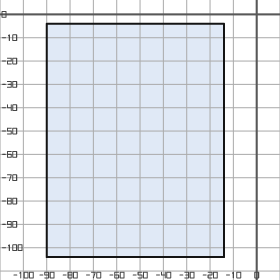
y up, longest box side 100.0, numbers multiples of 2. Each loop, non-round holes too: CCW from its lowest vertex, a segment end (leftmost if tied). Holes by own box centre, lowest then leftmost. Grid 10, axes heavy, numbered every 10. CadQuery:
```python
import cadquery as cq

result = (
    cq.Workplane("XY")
    .moveTo(-90.0, -104.0)
    .lineTo(-14.0, -104.0)
    .lineTo(-14.0, -4.0)
    .lineTo(-90.0, -4.0)
    .close()
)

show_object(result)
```